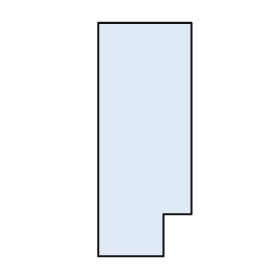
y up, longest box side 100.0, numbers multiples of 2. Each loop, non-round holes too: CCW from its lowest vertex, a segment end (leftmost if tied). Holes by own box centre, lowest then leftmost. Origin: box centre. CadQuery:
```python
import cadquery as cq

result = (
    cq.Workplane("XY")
    .moveTo(-20.0, -50.0)
    .lineTo(8.0, -50.0)
    .lineTo(8.0, -32.0)
    .lineTo(20.0, -32.0)
    .lineTo(20.0, 50.0)
    .lineTo(-20.0, 50.0)
    .close()
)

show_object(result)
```